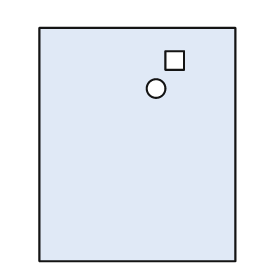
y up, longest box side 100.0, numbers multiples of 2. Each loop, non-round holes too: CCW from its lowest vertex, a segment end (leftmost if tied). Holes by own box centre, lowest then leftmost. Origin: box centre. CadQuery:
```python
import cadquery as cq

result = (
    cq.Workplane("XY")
    .moveTo(-42.0, -50.0)
    .lineTo(42.0, -50.0)
    .lineTo(42.0, 50.0)
    .lineTo(-42.0, 50.0)
    .close()
    .moveTo(8.0, 24.0)
    .circle(4.0)
    .moveTo(12.0, 32.0)
    .lineTo(20.0, 32.0)
    .lineTo(20.0, 40.0)
    .lineTo(12.0, 40.0)
    .close()
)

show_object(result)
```